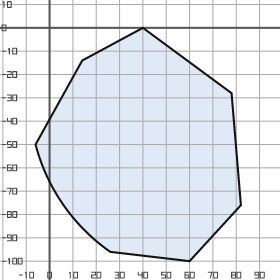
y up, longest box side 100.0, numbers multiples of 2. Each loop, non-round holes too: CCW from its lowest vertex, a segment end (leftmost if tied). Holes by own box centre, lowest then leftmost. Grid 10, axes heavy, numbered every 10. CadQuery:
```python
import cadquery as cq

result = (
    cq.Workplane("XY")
    .moveTo(60.0, -100.0)
    .lineTo(82.0, -76.0)
    .lineTo(78.0, -28.0)
    .lineTo(40.0, 0.0)
    .lineTo(14.0, -14.0)
    .lineTo(-6.0, -50.0)
    .threePointArc((6.0, -76.0), (26.0, -96.0))
    .close()
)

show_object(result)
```